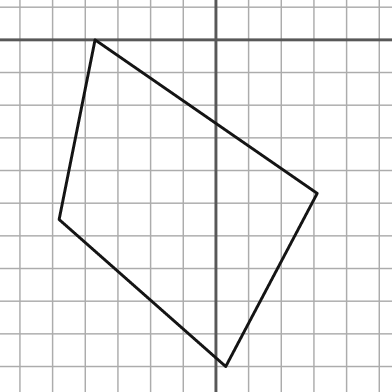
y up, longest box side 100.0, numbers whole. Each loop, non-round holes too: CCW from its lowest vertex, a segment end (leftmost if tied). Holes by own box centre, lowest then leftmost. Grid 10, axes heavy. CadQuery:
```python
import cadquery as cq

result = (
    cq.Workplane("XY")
    .moveTo(3.0, -100.0)
    .lineTo(31.0, -47.0)
    .lineTo(-37.0, 0.0)
    .lineTo(-48.0, -55.0)
    .close()
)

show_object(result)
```